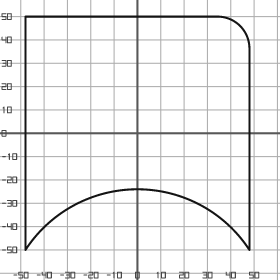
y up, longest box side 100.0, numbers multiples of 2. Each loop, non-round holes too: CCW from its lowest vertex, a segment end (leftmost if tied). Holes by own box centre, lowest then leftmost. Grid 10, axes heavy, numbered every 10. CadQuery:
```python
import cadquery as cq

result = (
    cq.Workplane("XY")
    .moveTo(-48.0, -50.0)
    .threePointArc((0.0, -24.0), (48.0, -50.0))
    .lineTo(48.0, 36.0)
    .threePointArc((44.0, 46.0), (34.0, 50.0))
    .lineTo(-48.0, 50.0)
    .close()
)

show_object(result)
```